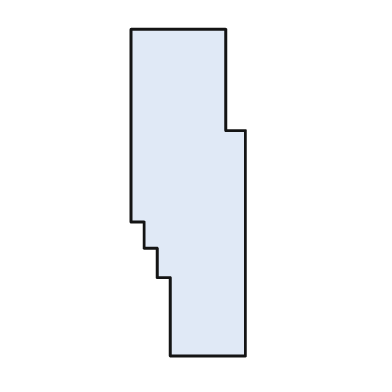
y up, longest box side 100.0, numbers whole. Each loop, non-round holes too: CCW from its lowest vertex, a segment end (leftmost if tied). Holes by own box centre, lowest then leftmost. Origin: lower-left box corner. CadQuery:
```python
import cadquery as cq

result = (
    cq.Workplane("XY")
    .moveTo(12.0, 0.0)
    .lineTo(35.0, 0.0)
    .lineTo(35.0, 69.0)
    .lineTo(29.0, 69.0)
    .lineTo(29.0, 100.0)
    .lineTo(0.0, 100.0)
    .lineTo(0.0, 41.0)
    .lineTo(4.0, 41.0)
    .lineTo(4.0, 33.0)
    .lineTo(8.0, 33.0)
    .lineTo(8.0, 24.0)
    .lineTo(12.0, 24.0)
    .close()
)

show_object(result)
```